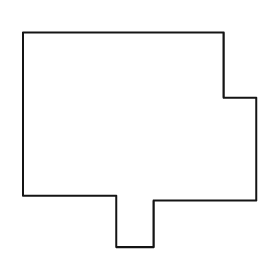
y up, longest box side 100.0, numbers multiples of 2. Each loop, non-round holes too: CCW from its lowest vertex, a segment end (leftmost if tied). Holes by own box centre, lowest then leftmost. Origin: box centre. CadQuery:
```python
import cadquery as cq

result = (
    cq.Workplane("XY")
    .moveTo(-10.0, -46.0)
    .lineTo(6.0, -46.0)
    .lineTo(6.0, -26.0)
    .lineTo(50.0, -26.0)
    .lineTo(50.0, 18.0)
    .lineTo(36.0, 18.0)
    .lineTo(36.0, 46.0)
    .lineTo(-50.0, 46.0)
    .lineTo(-50.0, -24.0)
    .lineTo(-10.0, -24.0)
    .close()
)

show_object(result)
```